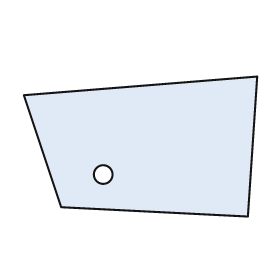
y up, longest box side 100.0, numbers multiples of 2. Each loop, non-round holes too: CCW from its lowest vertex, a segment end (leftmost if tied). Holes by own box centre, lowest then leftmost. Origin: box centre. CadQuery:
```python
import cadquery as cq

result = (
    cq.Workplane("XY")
    .moveTo(46.0, -30.0)
    .lineTo(50.0, 30.0)
    .lineTo(-50.0, 22.0)
    .lineTo(-34.0, -26.0)
    .close()
    .moveTo(-16.0, -12.0)
    .circle(4.0)
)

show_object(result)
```